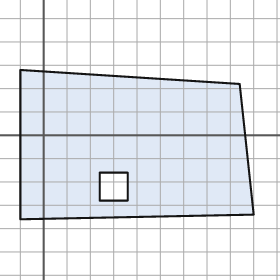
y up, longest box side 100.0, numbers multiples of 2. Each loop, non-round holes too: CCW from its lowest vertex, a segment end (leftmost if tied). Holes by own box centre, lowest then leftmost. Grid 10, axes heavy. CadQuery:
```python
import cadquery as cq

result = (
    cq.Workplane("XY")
    .moveTo(-10.0, -36.0)
    .lineTo(90.0, -34.0)
    .lineTo(84.0, 22.0)
    .lineTo(-10.0, 28.0)
    .close()
    .moveTo(24.0, -28.0)
    .lineTo(36.0, -28.0)
    .lineTo(36.0, -16.0)
    .lineTo(24.0, -16.0)
    .close()
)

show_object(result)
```